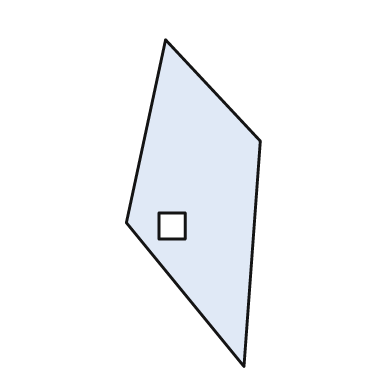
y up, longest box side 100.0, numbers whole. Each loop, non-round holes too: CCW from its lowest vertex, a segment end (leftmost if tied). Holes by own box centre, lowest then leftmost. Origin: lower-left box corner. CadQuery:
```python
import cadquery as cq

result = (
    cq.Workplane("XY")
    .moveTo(36.0, 0.0)
    .lineTo(41.0, 69.0)
    .lineTo(12.0, 100.0)
    .lineTo(0.0, 44.0)
    .close()
    .moveTo(10.0, 39.0)
    .lineTo(18.0, 39.0)
    .lineTo(18.0, 47.0)
    .lineTo(10.0, 47.0)
    .close()
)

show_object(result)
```